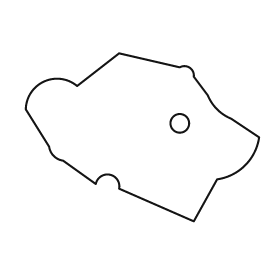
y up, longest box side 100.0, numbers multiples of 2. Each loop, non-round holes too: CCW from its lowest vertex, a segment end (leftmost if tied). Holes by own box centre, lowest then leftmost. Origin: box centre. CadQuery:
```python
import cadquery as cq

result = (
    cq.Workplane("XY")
    .moveTo(22.0, -36.0)
    .lineTo(32.0, -18.0)
    .threePointArc((44.0, -12.0), (50.0, 0.0))
    .lineTo(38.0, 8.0)
    .threePointArc((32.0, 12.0), (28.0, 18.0))
    .lineTo(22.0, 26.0)
    .threePointArc((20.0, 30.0), (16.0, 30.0))
    .lineTo(-10.0, 36.0)
    .lineTo(-28.0, 22.0)
    .threePointArc((-42.0, 24.0), (-50.0, 12.0))
    .lineTo(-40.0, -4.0)
    .threePointArc((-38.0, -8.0), (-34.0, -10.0))
    .lineTo(-20.0, -20.0)
    .threePointArc((-14.0, -16.0), (-10.0, -22.0))
    .close()
    .moveTo(16.0, 6.0)
    .circle(4.0)
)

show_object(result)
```